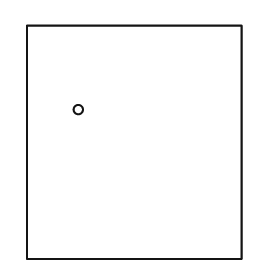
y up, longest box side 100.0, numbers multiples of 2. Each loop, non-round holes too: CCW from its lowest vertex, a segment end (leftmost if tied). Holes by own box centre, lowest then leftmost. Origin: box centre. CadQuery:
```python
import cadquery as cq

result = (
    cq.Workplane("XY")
    .moveTo(-46.0, -50.0)
    .lineTo(46.0, -50.0)
    .lineTo(46.0, 50.0)
    .lineTo(-46.0, 50.0)
    .close()
    .moveTo(-24.0, 14.0)
    .circle(2.0)
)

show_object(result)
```